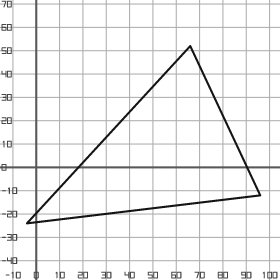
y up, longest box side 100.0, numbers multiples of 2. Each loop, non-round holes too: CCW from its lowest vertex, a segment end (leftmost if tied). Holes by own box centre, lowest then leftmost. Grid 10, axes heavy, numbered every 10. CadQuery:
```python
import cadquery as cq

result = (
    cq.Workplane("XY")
    .moveTo(-4.0, -24.0)
    .lineTo(96.0, -12.0)
    .lineTo(66.0, 52.0)
    .close()
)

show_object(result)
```